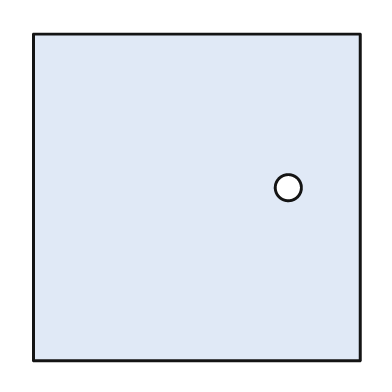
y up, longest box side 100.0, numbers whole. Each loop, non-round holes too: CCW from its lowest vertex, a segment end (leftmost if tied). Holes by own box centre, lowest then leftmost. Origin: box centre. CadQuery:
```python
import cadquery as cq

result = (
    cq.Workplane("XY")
    .moveTo(-50.0, -50.0)
    .lineTo(50.0, -50.0)
    .lineTo(50.0, 50.0)
    .lineTo(-50.0, 50.0)
    .close()
    .moveTo(28.0, 3.0)
    .circle(4.0)
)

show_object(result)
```